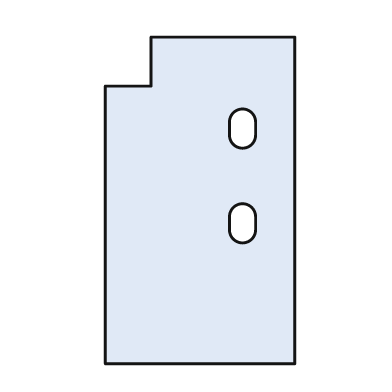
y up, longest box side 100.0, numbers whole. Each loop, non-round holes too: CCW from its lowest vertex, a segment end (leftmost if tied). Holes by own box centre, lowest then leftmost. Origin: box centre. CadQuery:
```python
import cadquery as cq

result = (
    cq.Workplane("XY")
    .moveTo(-29.0, -50.0)
    .lineTo(29.0, -50.0)
    .lineTo(29.0, 50.0)
    .lineTo(-15.0, 50.0)
    .lineTo(-15.0, 35.0)
    .lineTo(-29.0, 35.0)
    .close()
    .moveTo(9.0, -9.0)
    .threePointArc((13.0, -13.0), (17.0, -9.0))
    .lineTo(17.0, -5.0)
    .threePointArc((13.0, -1.0), (9.0, -5.0))
    .close()
    .moveTo(9.0, 20.0)
    .threePointArc((13.0, 16.0), (17.0, 20.0))
    .lineTo(17.0, 24.0)
    .threePointArc((13.0, 28.0), (9.0, 24.0))
    .close()
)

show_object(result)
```